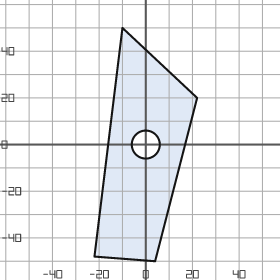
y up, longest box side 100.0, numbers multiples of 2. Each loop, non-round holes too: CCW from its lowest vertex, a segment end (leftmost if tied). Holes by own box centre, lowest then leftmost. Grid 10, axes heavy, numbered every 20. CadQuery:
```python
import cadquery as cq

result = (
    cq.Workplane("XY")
    .moveTo(4.0, -50.0)
    .lineTo(22.0, 20.0)
    .lineTo(-10.0, 50.0)
    .lineTo(-22.0, -48.0)
    .close()
    .moveTo(0.0, 0.0)
    .circle(6.0)
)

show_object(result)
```